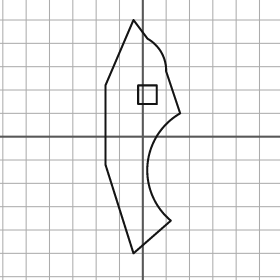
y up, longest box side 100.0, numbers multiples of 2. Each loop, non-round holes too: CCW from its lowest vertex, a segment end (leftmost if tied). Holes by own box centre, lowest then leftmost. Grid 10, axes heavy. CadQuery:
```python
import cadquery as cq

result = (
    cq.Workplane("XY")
    .moveTo(-4.0, -50.0)
    .lineTo(12.0, -36.0)
    .threePointArc((2.0, -12.0), (16.0, 10.0))
    .lineTo(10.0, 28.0)
    .threePointArc((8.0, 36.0), (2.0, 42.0))
    .lineTo(-4.0, 50.0)
    .lineTo(-16.0, 22.0)
    .lineTo(-16.0, -12.0)
    .close()
    .moveTo(-2.0, 14.0)
    .lineTo(6.0, 14.0)
    .lineTo(6.0, 22.0)
    .lineTo(-2.0, 22.0)
    .close()
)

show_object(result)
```